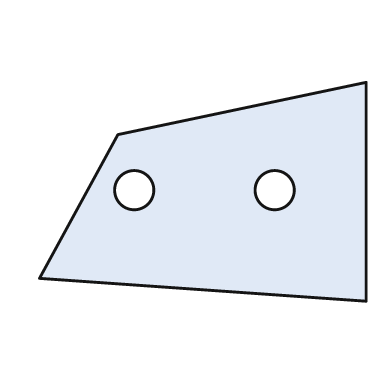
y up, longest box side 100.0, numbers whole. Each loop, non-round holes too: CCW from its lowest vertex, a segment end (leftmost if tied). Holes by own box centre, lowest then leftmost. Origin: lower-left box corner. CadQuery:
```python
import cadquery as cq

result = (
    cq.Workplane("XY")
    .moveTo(100.0, 0.0)
    .lineTo(100.0, 67.0)
    .lineTo(24.0, 51.0)
    .lineTo(0.0, 7.0)
    .close()
    .moveTo(29.0, 34.0)
    .circle(6.0)
    .moveTo(72.0, 34.0)
    .circle(6.0)
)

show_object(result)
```